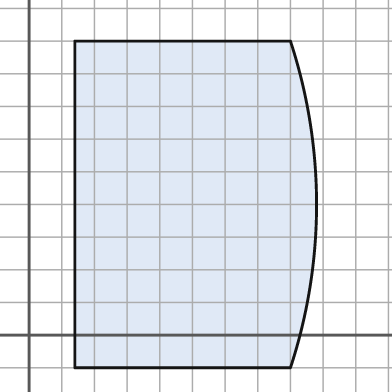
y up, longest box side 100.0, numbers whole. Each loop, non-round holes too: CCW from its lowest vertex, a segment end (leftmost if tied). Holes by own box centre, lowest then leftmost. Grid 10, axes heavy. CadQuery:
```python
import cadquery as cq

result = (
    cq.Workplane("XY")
    .moveTo(14.0, -10.0)
    .lineTo(80.0, -10.0)
    .threePointArc((88.0, 40.0), (80.0, 90.0))
    .lineTo(14.0, 90.0)
    .close()
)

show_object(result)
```